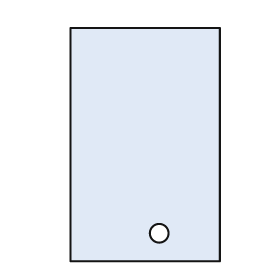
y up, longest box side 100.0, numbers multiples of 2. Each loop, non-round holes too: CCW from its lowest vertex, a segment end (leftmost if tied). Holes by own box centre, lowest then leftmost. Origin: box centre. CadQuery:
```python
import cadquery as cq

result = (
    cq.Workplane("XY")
    .moveTo(-32.0, -50.0)
    .lineTo(32.0, -50.0)
    .lineTo(32.0, 50.0)
    .lineTo(-32.0, 50.0)
    .close()
    .moveTo(6.0, -38.0)
    .circle(4.0)
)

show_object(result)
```